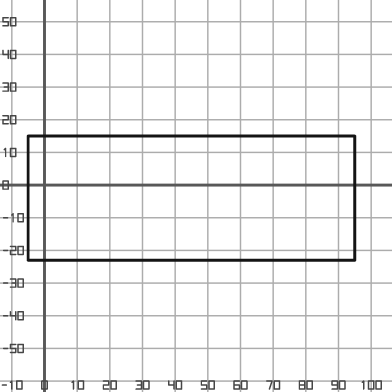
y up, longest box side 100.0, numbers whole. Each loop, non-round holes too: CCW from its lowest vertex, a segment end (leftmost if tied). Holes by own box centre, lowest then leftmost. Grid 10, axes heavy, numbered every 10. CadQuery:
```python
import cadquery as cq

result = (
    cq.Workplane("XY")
    .moveTo(-5.0, -23.0)
    .lineTo(95.0, -23.0)
    .lineTo(95.0, 15.0)
    .lineTo(-5.0, 15.0)
    .close()
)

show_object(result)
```